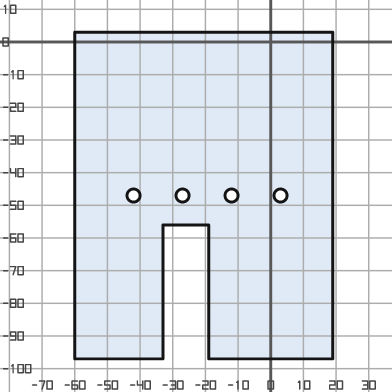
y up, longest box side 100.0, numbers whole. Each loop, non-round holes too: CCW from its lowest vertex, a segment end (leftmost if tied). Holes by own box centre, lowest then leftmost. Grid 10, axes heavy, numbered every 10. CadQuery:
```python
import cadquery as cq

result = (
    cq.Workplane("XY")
    .moveTo(-60.0, -97.0)
    .lineTo(-33.0, -97.0)
    .lineTo(-33.0, -56.0)
    .lineTo(-19.0, -56.0)
    .lineTo(-19.0, -97.0)
    .lineTo(19.0, -97.0)
    .lineTo(19.0, 3.0)
    .lineTo(-60.0, 3.0)
    .close()
    .moveTo(-42.0, -47.0)
    .circle(2.0)
    .moveTo(-27.0, -47.0)
    .circle(2.0)
    .moveTo(-12.0, -47.0)
    .circle(2.0)
    .moveTo(3.0, -47.0)
    .circle(2.0)
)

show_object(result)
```